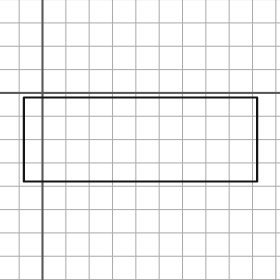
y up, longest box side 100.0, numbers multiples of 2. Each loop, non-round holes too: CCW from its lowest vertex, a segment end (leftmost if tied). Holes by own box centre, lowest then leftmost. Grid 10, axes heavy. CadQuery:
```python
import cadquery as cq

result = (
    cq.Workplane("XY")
    .moveTo(-8.0, -38.0)
    .lineTo(92.0, -38.0)
    .lineTo(92.0, -2.0)
    .lineTo(-8.0, -2.0)
    .close()
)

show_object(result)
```